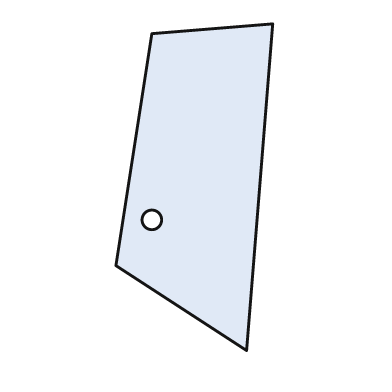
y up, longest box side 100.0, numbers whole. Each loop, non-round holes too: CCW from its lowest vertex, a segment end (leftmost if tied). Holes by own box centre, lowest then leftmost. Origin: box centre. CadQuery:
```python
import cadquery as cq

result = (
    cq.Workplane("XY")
    .moveTo(16.0, -50.0)
    .lineTo(24.0, 50.0)
    .lineTo(-13.0, 47.0)
    .lineTo(-24.0, -24.0)
    .close()
    .moveTo(-13.0, -10.0)
    .circle(3.0)
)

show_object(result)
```